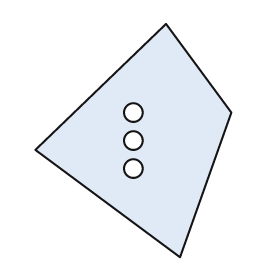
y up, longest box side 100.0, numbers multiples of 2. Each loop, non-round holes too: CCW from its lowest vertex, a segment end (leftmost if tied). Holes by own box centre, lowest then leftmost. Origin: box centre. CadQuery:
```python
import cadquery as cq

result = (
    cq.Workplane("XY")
    .moveTo(20.0, -50.0)
    .lineTo(42.0, 12.0)
    .lineTo(14.0, 50.0)
    .lineTo(-42.0, -4.0)
    .close()
    .moveTo(0.0, -12.0)
    .circle(4.0)
    .moveTo(0.0, 0.0)
    .circle(4.0)
    .moveTo(0.0, 12.0)
    .circle(4.0)
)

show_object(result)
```